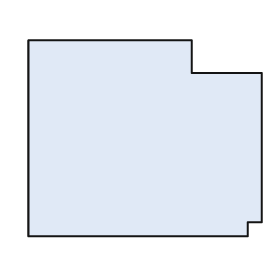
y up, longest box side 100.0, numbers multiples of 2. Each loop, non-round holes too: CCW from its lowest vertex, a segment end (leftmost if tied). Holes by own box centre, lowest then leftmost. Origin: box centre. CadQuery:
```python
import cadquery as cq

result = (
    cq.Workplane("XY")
    .moveTo(-50.0, -42.0)
    .lineTo(44.0, -42.0)
    .lineTo(44.0, -36.0)
    .lineTo(50.0, -36.0)
    .lineTo(50.0, 28.0)
    .lineTo(20.0, 28.0)
    .lineTo(20.0, 42.0)
    .lineTo(-50.0, 42.0)
    .close()
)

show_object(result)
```